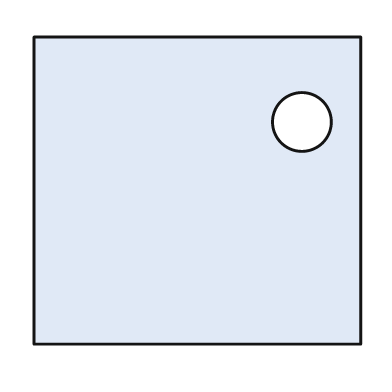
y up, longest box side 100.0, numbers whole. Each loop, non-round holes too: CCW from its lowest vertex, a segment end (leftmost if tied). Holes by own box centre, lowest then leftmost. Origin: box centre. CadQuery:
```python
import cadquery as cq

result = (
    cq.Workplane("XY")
    .moveTo(-50.0, -47.0)
    .lineTo(50.0, -47.0)
    .lineTo(50.0, 47.0)
    .lineTo(-50.0, 47.0)
    .close()
    .moveTo(32.0, 21.0)
    .circle(9.0)
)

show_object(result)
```